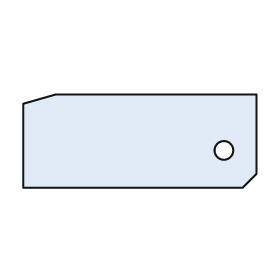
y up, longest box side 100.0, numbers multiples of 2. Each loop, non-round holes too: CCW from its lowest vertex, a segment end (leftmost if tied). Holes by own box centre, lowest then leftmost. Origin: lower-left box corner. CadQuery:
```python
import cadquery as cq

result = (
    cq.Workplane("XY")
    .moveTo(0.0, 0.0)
    .lineTo(94.0, 0.0)
    .lineTo(100.0, 6.0)
    .lineTo(100.0, 40.0)
    .lineTo(14.0, 40.0)
    .lineTo(0.0, 36.0)
    .close()
    .moveTo(86.0, 16.0)
    .circle(4.0)
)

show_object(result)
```